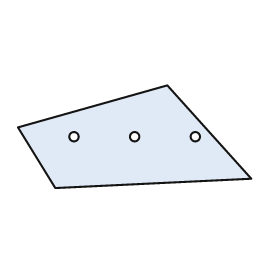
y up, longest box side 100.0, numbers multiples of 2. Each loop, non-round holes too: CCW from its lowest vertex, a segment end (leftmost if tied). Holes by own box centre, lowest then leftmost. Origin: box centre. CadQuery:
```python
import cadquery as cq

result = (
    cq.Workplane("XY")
    .moveTo(-34.0, -22.0)
    .lineTo(50.0, -18.0)
    .lineTo(14.0, 22.0)
    .lineTo(-50.0, 4.0)
    .close()
    .moveTo(-26.0, 0.0)
    .circle(2.0)
    .moveTo(0.0, 0.0)
    .circle(2.0)
    .moveTo(26.0, 0.0)
    .circle(2.0)
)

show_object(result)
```